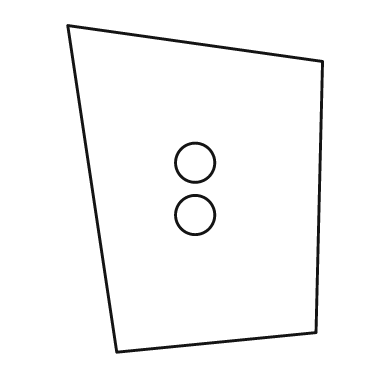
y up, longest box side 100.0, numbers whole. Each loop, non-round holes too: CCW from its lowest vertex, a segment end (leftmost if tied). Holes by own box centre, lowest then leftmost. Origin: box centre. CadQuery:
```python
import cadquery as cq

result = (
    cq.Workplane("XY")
    .moveTo(-24.0, -50.0)
    .lineTo(37.0, -44.0)
    .lineTo(39.0, 39.0)
    .lineTo(-39.0, 50.0)
    .close()
    .moveTo(0.0, -8.0)
    .circle(6.0)
    .moveTo(0.0, 8.0)
    .circle(6.0)
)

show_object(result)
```